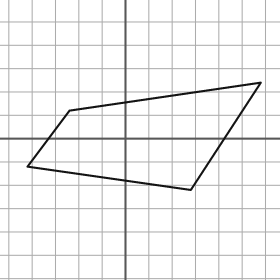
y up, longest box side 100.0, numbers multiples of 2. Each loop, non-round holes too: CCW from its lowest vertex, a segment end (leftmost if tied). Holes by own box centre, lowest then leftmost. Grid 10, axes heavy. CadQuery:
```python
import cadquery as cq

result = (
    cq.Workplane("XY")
    .moveTo(28.0, -22.0)
    .lineTo(58.0, 24.0)
    .lineTo(-24.0, 12.0)
    .lineTo(-42.0, -12.0)
    .close()
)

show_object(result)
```